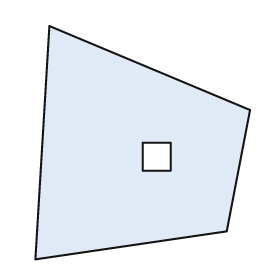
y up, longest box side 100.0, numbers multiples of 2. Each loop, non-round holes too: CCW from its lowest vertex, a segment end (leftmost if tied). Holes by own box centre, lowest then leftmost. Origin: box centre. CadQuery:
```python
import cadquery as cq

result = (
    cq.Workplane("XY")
    .moveTo(-46.0, -50.0)
    .lineTo(36.0, -38.0)
    .lineTo(46.0, 14.0)
    .lineTo(-40.0, 50.0)
    .close()
    .moveTo(0.0, -12.0)
    .lineTo(12.0, -12.0)
    .lineTo(12.0, 0.0)
    .lineTo(0.0, 0.0)
    .close()
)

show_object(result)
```